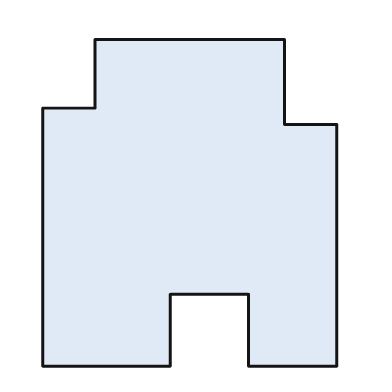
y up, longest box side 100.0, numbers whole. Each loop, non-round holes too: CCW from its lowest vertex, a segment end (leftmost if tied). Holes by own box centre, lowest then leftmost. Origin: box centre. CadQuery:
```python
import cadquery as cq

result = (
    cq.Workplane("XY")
    .moveTo(-45.0, -50.0)
    .lineTo(-6.0, -50.0)
    .lineTo(-6.0, -28.0)
    .lineTo(18.0, -28.0)
    .lineTo(18.0, -50.0)
    .lineTo(45.0, -50.0)
    .lineTo(45.0, 24.0)
    .lineTo(29.0, 24.0)
    .lineTo(29.0, 50.0)
    .lineTo(-29.0, 50.0)
    .lineTo(-29.0, 29.0)
    .lineTo(-45.0, 29.0)
    .close()
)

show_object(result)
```